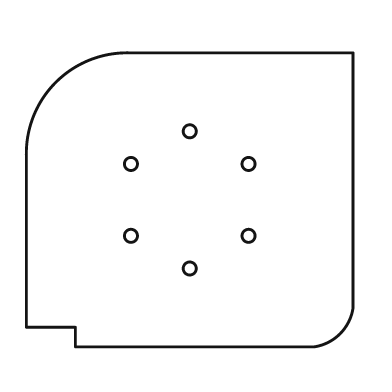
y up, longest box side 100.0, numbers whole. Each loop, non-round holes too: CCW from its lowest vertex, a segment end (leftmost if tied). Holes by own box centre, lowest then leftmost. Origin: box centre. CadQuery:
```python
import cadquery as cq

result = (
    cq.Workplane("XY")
    .moveTo(-35.0, -45.0)
    .lineTo(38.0, -45.0)
    .threePointArc((46.0, -41.0), (50.0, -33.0))
    .lineTo(50.0, 45.0)
    .lineTo(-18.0, 45.0)
    .threePointArc((-41.0, 36.0), (-50.0, 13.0))
    .lineTo(-50.0, -39.0)
    .lineTo(-35.0, -39.0)
    .close()
    .moveTo(0.0, -21.0)
    .circle(2.0)
    .moveTo(-18.0, -11.0)
    .circle(2.0)
    .moveTo(18.0, -11.0)
    .circle(2.0)
    .moveTo(-18.0, 11.0)
    .circle(2.0)
    .moveTo(18.0, 11.0)
    .circle(2.0)
    .moveTo(0.0, 21.0)
    .circle(2.0)
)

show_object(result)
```